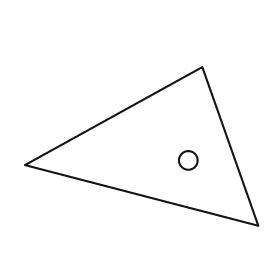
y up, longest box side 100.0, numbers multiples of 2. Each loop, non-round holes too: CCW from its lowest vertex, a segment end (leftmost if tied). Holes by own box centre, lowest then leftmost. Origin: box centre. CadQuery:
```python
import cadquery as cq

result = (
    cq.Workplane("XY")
    .moveTo(50.0, -34.0)
    .lineTo(26.0, 34.0)
    .lineTo(-50.0, -8.0)
    .close()
    .moveTo(20.0, -6.0)
    .circle(4.0)
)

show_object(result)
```